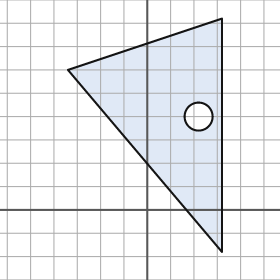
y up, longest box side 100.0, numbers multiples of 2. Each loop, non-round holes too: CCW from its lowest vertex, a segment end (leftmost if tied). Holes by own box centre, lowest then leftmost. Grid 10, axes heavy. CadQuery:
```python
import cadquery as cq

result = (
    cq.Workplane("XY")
    .moveTo(32.0, -18.0)
    .lineTo(32.0, 82.0)
    .lineTo(-34.0, 60.0)
    .close()
    .moveTo(22.0, 40.0)
    .circle(6.0)
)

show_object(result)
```